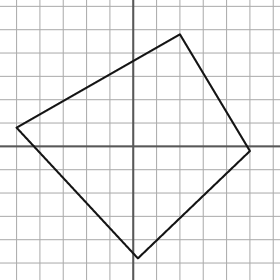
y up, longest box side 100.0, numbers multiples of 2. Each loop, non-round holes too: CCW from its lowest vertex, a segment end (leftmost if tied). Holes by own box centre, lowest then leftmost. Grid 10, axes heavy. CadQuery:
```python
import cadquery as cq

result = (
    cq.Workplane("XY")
    .moveTo(2.0, -48.0)
    .lineTo(50.0, -2.0)
    .lineTo(20.0, 48.0)
    .lineTo(-50.0, 8.0)
    .close()
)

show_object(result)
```